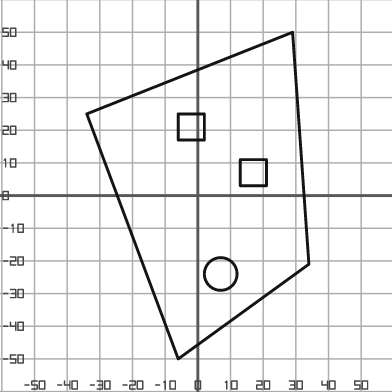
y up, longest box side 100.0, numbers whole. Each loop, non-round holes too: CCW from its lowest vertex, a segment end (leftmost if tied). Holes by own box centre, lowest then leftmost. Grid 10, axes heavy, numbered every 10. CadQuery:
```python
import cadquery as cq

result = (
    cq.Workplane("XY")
    .moveTo(-6.0, -50.0)
    .lineTo(34.0, -21.0)
    .lineTo(29.0, 50.0)
    .lineTo(-34.0, 25.0)
    .close()
    .moveTo(7.0, -24.0)
    .circle(5.0)
    .moveTo(13.0, 3.0)
    .lineTo(21.0, 3.0)
    .lineTo(21.0, 11.0)
    .lineTo(13.0, 11.0)
    .close()
    .moveTo(-6.0, 17.0)
    .lineTo(2.0, 17.0)
    .lineTo(2.0, 25.0)
    .lineTo(-6.0, 25.0)
    .close()
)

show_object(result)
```